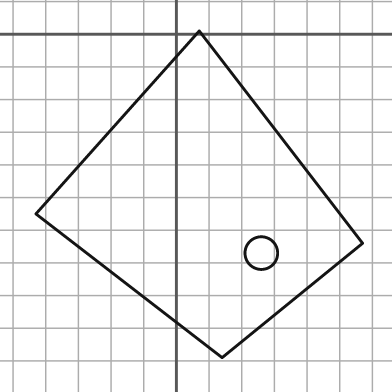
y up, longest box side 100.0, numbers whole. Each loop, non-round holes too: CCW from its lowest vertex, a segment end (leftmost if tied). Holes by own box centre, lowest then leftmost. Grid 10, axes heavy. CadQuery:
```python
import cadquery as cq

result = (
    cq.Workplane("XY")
    .moveTo(14.0, -99.0)
    .lineTo(57.0, -64.0)
    .lineTo(7.0, 1.0)
    .lineTo(-43.0, -55.0)
    .close()
    .moveTo(26.0, -67.0)
    .circle(5.0)
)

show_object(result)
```